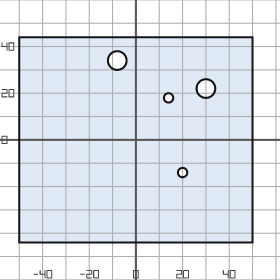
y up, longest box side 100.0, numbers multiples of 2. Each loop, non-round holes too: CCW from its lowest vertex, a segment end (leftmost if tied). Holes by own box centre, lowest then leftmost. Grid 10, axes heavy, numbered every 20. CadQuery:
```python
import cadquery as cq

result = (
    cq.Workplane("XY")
    .moveTo(-50.0, -44.0)
    .lineTo(50.0, -44.0)
    .lineTo(50.0, 44.0)
    .lineTo(-50.0, 44.0)
    .close()
    .moveTo(20.0, -14.0)
    .circle(2.0)
    .moveTo(14.0, 18.0)
    .circle(2.0)
    .moveTo(30.0, 22.0)
    .circle(4.0)
    .moveTo(-8.0, 34.0)
    .circle(4.0)
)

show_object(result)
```